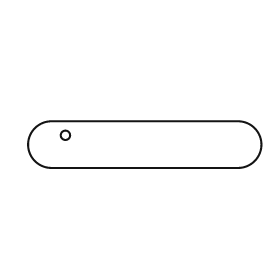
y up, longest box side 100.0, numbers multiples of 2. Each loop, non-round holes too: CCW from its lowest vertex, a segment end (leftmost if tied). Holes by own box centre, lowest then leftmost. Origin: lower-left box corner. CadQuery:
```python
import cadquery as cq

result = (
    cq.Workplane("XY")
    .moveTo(10.0, 0.0)
    .lineTo(90.0, 0.0)
    .threePointArc((100.0, 10.0), (90.0, 20.0))
    .lineTo(10.0, 20.0)
    .threePointArc((0.0, 10.0), (10.0, 0.0))
    .close()
    .moveTo(16.0, 14.0)
    .circle(2.0)
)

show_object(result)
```